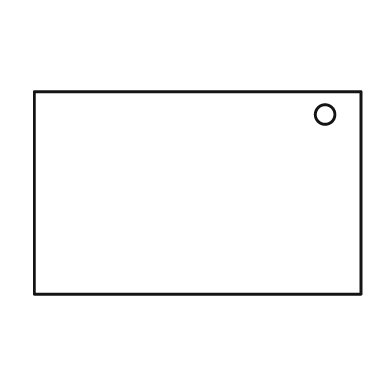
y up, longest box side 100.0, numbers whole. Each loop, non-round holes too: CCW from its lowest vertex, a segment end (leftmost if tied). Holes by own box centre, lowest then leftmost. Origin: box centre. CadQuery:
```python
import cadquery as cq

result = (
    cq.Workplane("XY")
    .moveTo(-50.0, -31.0)
    .lineTo(50.0, -31.0)
    .lineTo(50.0, 31.0)
    .lineTo(-50.0, 31.0)
    .close()
    .moveTo(39.0, 24.0)
    .circle(3.0)
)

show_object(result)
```